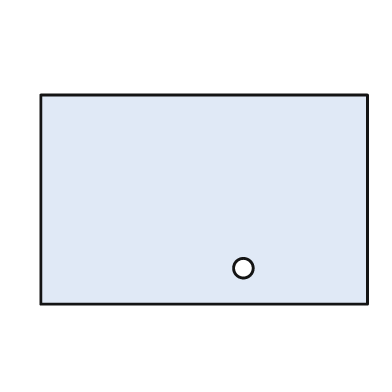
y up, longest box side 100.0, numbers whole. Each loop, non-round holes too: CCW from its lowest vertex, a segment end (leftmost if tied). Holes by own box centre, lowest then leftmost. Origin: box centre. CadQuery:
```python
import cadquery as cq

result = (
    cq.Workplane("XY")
    .moveTo(-50.0, -32.0)
    .lineTo(50.0, -32.0)
    .lineTo(50.0, 32.0)
    .lineTo(-50.0, 32.0)
    .close()
    .moveTo(12.0, -21.0)
    .circle(3.0)
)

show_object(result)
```